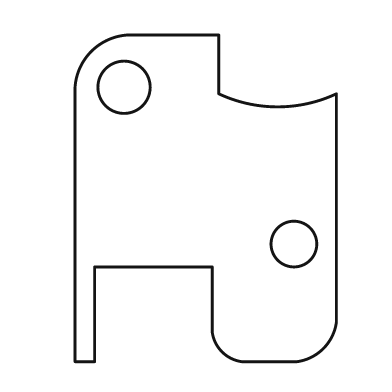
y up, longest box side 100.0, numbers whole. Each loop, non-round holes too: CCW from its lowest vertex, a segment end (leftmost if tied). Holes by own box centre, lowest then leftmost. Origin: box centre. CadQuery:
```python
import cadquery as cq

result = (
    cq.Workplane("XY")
    .moveTo(-40.0, -50.0)
    .lineTo(-34.0, -50.0)
    .lineTo(-34.0, -21.0)
    .lineTo(2.0, -21.0)
    .lineTo(2.0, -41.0)
    .threePointArc((5.0, -47.0), (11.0, -50.0))
    .lineTo(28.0, -50.0)
    .threePointArc((36.0, -46.0), (40.0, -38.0))
    .lineTo(40.0, 32.0)
    .threePointArc((22.0, 28.0), (4.0, 32.0))
    .lineTo(4.0, 50.0)
    .lineTo(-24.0, 50.0)
    .threePointArc((-35.0, 45.0), (-40.0, 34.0))
    .close()
    .moveTo(27.0, -14.0)
    .circle(7.0)
    .moveTo(-25.0, 34.0)
    .circle(8.0)
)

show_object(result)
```